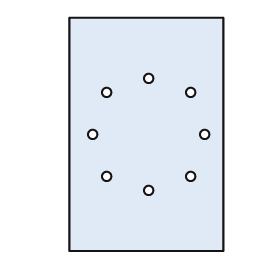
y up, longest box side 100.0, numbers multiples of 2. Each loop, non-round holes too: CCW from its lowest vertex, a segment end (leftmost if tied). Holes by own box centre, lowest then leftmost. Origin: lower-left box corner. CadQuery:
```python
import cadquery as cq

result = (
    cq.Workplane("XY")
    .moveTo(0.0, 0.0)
    .lineTo(66.0, 0.0)
    .lineTo(66.0, 100.0)
    .lineTo(0.0, 100.0)
    .close()
    .moveTo(34.0, 26.0)
    .circle(2.0)
    .moveTo(16.0, 32.0)
    .circle(2.0)
    .moveTo(52.0, 32.0)
    .circle(2.0)
    .moveTo(10.0, 50.0)
    .circle(2.0)
    .moveTo(58.0, 50.0)
    .circle(2.0)
    .moveTo(16.0, 68.0)
    .circle(2.0)
    .moveTo(52.0, 68.0)
    .circle(2.0)
    .moveTo(34.0, 74.0)
    .circle(2.0)
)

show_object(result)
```